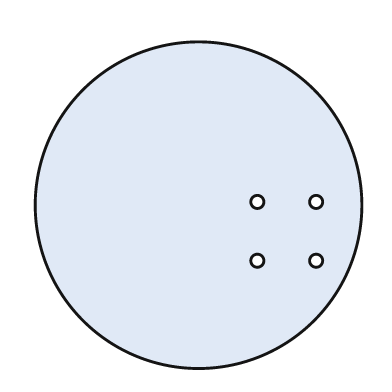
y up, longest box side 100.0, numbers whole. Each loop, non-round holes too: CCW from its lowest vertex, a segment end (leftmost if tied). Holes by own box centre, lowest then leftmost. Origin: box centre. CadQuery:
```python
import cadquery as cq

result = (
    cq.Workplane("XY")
    .moveTo(0.0, 0.0)
    .circle(50.0)
    .moveTo(18.0, -17.0)
    .circle(2.0)
    .moveTo(36.0, -17.0)
    .circle(2.0)
    .moveTo(18.0, 1.0)
    .circle(2.0)
    .moveTo(36.0, 1.0)
    .circle(2.0)
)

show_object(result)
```